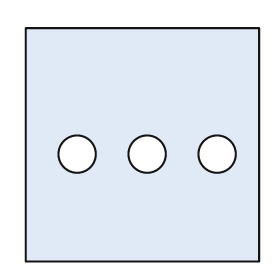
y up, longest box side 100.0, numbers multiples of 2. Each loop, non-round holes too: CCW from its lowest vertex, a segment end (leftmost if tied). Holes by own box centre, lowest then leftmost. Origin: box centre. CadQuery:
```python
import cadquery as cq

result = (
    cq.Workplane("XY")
    .moveTo(-50.0, -50.0)
    .lineTo(50.0, -50.0)
    .lineTo(50.0, 50.0)
    .lineTo(-50.0, 50.0)
    .close()
    .moveTo(-28.0, -4.0)
    .circle(8.0)
    .moveTo(2.0, -4.0)
    .circle(8.0)
    .moveTo(32.0, -4.0)
    .circle(8.0)
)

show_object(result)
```